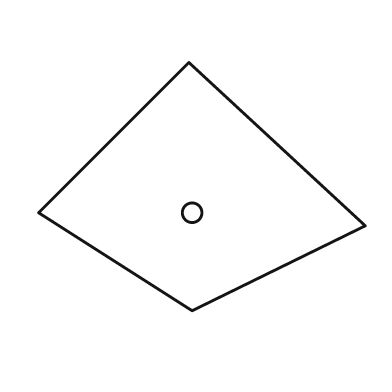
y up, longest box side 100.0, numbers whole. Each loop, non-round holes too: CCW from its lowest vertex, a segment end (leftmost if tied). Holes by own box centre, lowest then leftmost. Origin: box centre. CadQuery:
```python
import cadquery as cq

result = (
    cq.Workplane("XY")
    .moveTo(-3.0, -38.0)
    .lineTo(50.0, -12.0)
    .lineTo(-4.0, 38.0)
    .lineTo(-50.0, -8.0)
    .close()
    .moveTo(-3.0, -8.0)
    .circle(3.0)
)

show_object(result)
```